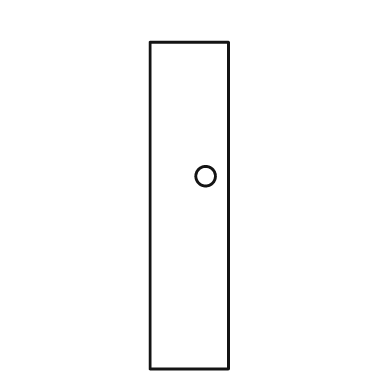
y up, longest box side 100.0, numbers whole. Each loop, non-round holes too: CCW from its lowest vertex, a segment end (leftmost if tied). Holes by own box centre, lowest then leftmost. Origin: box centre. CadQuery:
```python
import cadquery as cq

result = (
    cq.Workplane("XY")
    .moveTo(-12.0, -50.0)
    .lineTo(12.0, -50.0)
    .lineTo(12.0, 50.0)
    .lineTo(-12.0, 50.0)
    .close()
    .moveTo(5.0, 9.0)
    .circle(3.0)
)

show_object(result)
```